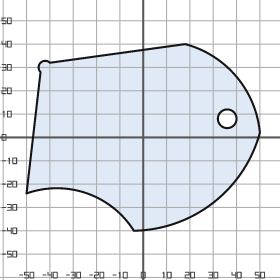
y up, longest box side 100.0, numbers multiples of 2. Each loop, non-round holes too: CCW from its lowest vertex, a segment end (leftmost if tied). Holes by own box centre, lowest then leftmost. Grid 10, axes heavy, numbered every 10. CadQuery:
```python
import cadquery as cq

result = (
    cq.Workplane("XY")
    .moveTo(-4.0, -40.0)
    .threePointArc((30.0, -28.0), (50.0, 2.0))
    .threePointArc((40.0, 26.0), (18.0, 40.0))
    .lineTo(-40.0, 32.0)
    .threePointArc((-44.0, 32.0), (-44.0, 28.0))
    .lineTo(-50.0, -24.0)
    .threePointArc((-24.0, -24.0), (-4.0, -40.0))
    .close()
    .moveTo(36.0, 8.0)
    .circle(4.0)
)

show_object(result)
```